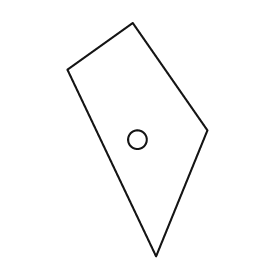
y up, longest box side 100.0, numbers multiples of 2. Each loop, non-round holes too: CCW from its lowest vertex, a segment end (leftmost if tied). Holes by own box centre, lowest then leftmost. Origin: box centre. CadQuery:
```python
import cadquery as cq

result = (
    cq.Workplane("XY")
    .moveTo(8.0, -50.0)
    .lineTo(30.0, 4.0)
    .lineTo(-2.0, 50.0)
    .lineTo(-30.0, 30.0)
    .close()
    .moveTo(0.0, 0.0)
    .circle(4.0)
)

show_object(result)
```